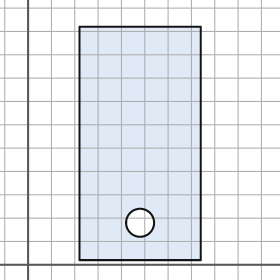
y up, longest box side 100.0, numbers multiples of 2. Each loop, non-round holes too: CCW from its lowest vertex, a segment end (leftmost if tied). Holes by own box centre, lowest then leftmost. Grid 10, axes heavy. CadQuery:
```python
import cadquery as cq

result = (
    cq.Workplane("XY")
    .moveTo(22.0, 2.0)
    .lineTo(74.0, 2.0)
    .lineTo(74.0, 102.0)
    .lineTo(22.0, 102.0)
    .close()
    .moveTo(48.0, 18.0)
    .circle(6.0)
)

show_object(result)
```